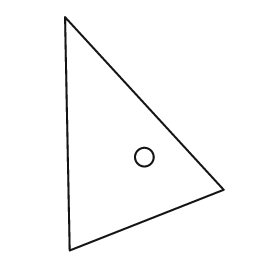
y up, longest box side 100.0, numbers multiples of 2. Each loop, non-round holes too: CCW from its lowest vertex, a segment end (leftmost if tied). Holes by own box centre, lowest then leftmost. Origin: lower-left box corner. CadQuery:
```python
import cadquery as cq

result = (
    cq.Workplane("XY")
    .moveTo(2.0, 0.0)
    .lineTo(68.0, 26.0)
    .lineTo(0.0, 100.0)
    .close()
    .moveTo(34.0, 40.0)
    .circle(4.0)
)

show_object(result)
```